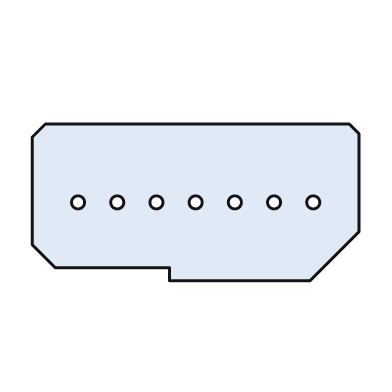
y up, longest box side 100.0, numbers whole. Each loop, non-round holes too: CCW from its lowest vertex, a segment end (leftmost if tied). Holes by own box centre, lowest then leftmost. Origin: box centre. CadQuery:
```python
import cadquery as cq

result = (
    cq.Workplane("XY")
    .moveTo(-8.0, -24.0)
    .lineTo(35.0, -24.0)
    .lineTo(50.0, -9.0)
    .lineTo(50.0, 21.0)
    .lineTo(47.0, 24.0)
    .lineTo(-46.0, 24.0)
    .lineTo(-50.0, 20.0)
    .lineTo(-50.0, -13.0)
    .lineTo(-43.0, -20.0)
    .lineTo(-8.0, -20.0)
    .close()
    .moveTo(-36.0, 0.0)
    .circle(2.0)
    .moveTo(-24.0, 0.0)
    .circle(2.0)
    .moveTo(-12.0, 0.0)
    .circle(2.0)
    .moveTo(0.0, 0.0)
    .circle(2.0)
    .moveTo(12.0, 0.0)
    .circle(2.0)
    .moveTo(24.0, 0.0)
    .circle(2.0)
    .moveTo(36.0, 0.0)
    .circle(2.0)
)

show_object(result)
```